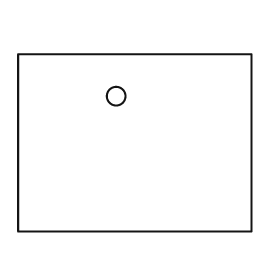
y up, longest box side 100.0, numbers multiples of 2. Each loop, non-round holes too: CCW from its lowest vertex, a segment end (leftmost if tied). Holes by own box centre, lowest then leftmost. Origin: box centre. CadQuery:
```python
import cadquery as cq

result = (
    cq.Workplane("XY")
    .moveTo(-50.0, -38.0)
    .lineTo(50.0, -38.0)
    .lineTo(50.0, 38.0)
    .lineTo(-50.0, 38.0)
    .close()
    .moveTo(-8.0, 20.0)
    .circle(4.0)
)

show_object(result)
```